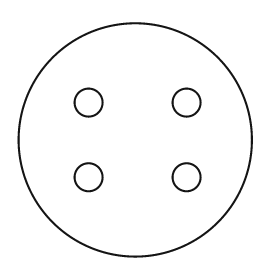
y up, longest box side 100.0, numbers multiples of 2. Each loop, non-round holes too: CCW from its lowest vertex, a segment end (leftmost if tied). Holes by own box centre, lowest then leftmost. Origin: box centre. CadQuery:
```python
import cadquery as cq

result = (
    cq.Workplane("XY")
    .moveTo(0.0, 0.0)
    .circle(50.0)
    .moveTo(-20.0, -16.0)
    .circle(6.0)
    .moveTo(22.0, -16.0)
    .circle(6.0)
    .moveTo(-20.0, 16.0)
    .circle(6.0)
    .moveTo(22.0, 16.0)
    .circle(6.0)
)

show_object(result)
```